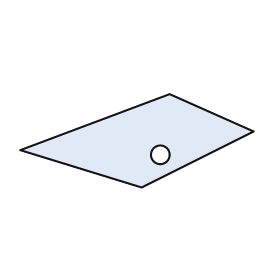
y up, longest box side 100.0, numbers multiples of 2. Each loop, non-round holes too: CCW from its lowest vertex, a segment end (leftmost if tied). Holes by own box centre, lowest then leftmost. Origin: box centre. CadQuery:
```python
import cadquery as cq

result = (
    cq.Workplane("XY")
    .moveTo(2.0, -20.0)
    .lineTo(50.0, 4.0)
    .lineTo(14.0, 20.0)
    .lineTo(-50.0, -4.0)
    .close()
    .moveTo(10.0, -6.0)
    .circle(4.0)
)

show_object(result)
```